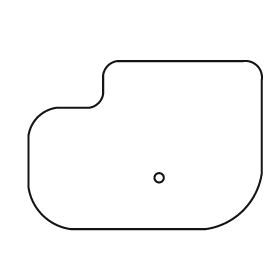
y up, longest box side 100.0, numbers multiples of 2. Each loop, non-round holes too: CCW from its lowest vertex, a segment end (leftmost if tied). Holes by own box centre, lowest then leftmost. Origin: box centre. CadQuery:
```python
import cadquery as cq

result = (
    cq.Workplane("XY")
    .moveTo(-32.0, -36.0)
    .lineTo(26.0, -36.0)
    .threePointArc((42.0, -28.0), (50.0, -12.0))
    .lineTo(50.0, 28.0)
    .threePointArc((48.0, 34.0), (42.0, 36.0))
    .lineTo(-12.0, 36.0)
    .threePointArc((-16.0, 34.0), (-18.0, 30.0))
    .lineTo(-18.0, 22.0)
    .threePointArc((-20.0, 18.0), (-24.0, 16.0))
    .lineTo(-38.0, 16.0)
    .threePointArc((-46.0, 12.0), (-50.0, 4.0))
    .lineTo(-50.0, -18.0)
    .threePointArc((-44.0, -30.0), (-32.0, -36.0))
    .close()
    .moveTo(6.0, -14.0)
    .circle(2.0)
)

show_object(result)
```